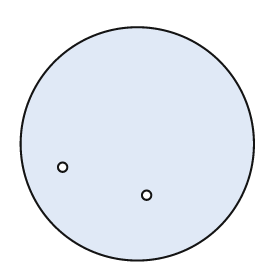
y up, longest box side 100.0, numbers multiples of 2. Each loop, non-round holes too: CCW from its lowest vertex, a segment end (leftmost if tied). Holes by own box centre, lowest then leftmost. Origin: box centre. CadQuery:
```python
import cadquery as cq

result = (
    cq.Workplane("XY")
    .moveTo(0.0, 0.0)
    .circle(50.0)
    .moveTo(4.0, -22.0)
    .circle(2.0)
    .moveTo(-32.0, -10.0)
    .circle(2.0)
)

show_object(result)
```